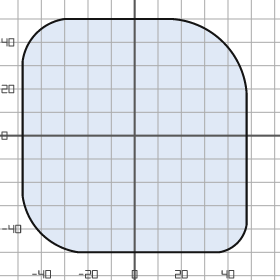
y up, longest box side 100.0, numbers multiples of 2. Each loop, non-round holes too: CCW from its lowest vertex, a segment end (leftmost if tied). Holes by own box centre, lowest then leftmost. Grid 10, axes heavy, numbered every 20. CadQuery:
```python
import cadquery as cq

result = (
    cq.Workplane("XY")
    .moveTo(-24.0, -50.0)
    .lineTo(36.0, -50.0)
    .threePointArc((44.0, -46.0), (48.0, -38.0))
    .lineTo(48.0, 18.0)
    .threePointArc((38.0, 40.0), (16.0, 50.0))
    .lineTo(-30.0, 50.0)
    .threePointArc((-42.0, 44.0), (-48.0, 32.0))
    .lineTo(-48.0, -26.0)
    .threePointArc((-40.0, -42.0), (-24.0, -50.0))
    .close()
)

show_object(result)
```